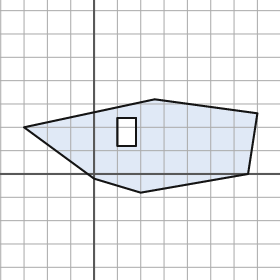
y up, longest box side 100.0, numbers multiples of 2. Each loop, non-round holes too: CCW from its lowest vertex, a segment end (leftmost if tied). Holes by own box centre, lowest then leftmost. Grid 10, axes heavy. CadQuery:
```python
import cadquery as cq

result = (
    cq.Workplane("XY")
    .moveTo(20.0, -8.0)
    .lineTo(66.0, 0.0)
    .lineTo(70.0, 26.0)
    .lineTo(26.0, 32.0)
    .lineTo(-30.0, 20.0)
    .lineTo(0.0, -2.0)
    .close()
    .moveTo(10.0, 12.0)
    .lineTo(18.0, 12.0)
    .lineTo(18.0, 24.0)
    .lineTo(10.0, 24.0)
    .close()
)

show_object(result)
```